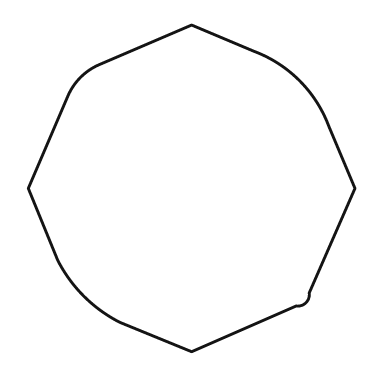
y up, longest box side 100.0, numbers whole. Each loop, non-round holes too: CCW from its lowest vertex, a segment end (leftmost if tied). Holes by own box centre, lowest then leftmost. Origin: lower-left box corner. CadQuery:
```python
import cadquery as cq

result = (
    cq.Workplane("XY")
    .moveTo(50.0, 0.0)
    .lineTo(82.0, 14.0)
    .threePointArc((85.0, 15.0), (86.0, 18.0))
    .lineTo(100.0, 50.0)
    .lineTo(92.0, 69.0)
    .threePointArc((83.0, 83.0), (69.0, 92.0))
    .lineTo(50.0, 100.0)
    .lineTo(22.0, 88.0)
    .threePointArc((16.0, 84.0), (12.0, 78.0))
    .lineTo(0.0, 50.0)
    .lineTo(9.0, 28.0)
    .threePointArc((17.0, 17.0), (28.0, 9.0))
    .close()
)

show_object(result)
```